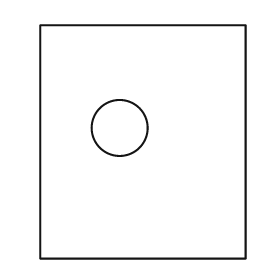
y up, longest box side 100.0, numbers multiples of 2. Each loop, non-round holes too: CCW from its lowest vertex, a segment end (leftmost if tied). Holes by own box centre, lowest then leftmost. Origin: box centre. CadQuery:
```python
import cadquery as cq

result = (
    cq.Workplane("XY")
    .moveTo(-44.0, -50.0)
    .lineTo(44.0, -50.0)
    .lineTo(44.0, 50.0)
    .lineTo(-44.0, 50.0)
    .close()
    .moveTo(-10.0, 6.0)
    .circle(12.0)
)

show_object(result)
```